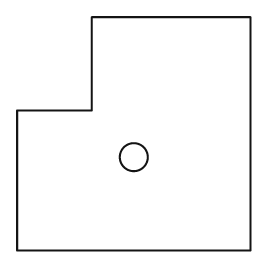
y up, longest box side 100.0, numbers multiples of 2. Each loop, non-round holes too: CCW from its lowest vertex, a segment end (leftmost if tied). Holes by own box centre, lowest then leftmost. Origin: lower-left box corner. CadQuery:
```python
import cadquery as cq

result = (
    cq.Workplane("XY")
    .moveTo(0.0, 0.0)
    .lineTo(100.0, 0.0)
    .lineTo(100.0, 100.0)
    .lineTo(32.0, 100.0)
    .lineTo(32.0, 60.0)
    .lineTo(0.0, 60.0)
    .close()
    .moveTo(50.0, 40.0)
    .circle(6.0)
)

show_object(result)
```